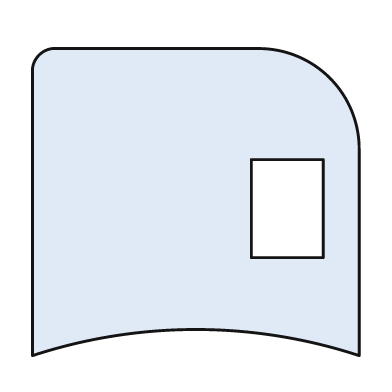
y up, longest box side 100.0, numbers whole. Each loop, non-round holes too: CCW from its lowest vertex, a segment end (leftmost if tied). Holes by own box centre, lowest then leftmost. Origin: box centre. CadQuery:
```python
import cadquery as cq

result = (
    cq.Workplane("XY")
    .moveTo(-50.0, -47.0)
    .threePointArc((0.0, -39.0), (50.0, -47.0))
    .lineTo(50.0, 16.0)
    .threePointArc((41.0, 38.0), (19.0, 47.0))
    .lineTo(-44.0, 47.0)
    .threePointArc((-48.0, 45.0), (-50.0, 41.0))
    .close()
    .moveTo(17.0, -17.0)
    .lineTo(39.0, -17.0)
    .lineTo(39.0, 13.0)
    .lineTo(17.0, 13.0)
    .close()
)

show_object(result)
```